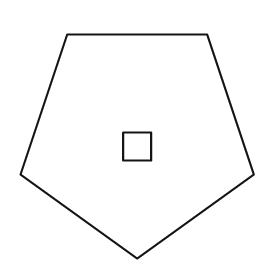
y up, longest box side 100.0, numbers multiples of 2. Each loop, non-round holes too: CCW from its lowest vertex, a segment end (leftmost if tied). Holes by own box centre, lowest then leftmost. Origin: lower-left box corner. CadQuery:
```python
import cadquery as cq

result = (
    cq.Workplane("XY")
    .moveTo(50.0, 0.0)
    .lineTo(100.0, 36.0)
    .lineTo(80.0, 96.0)
    .lineTo(20.0, 96.0)
    .lineTo(0.0, 36.0)
    .close()
    .moveTo(44.0, 42.0)
    .lineTo(56.0, 42.0)
    .lineTo(56.0, 54.0)
    .lineTo(44.0, 54.0)
    .close()
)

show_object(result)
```